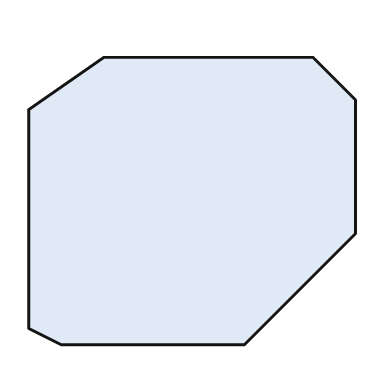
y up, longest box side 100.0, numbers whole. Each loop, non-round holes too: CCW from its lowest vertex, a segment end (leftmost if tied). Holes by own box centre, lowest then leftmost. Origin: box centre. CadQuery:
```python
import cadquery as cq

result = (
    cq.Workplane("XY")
    .moveTo(-40.0, -44.0)
    .lineTo(16.0, -44.0)
    .lineTo(50.0, -10.0)
    .lineTo(50.0, 31.0)
    .lineTo(37.0, 44.0)
    .lineTo(-27.0, 44.0)
    .lineTo(-50.0, 28.0)
    .lineTo(-50.0, -39.0)
    .close()
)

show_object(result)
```